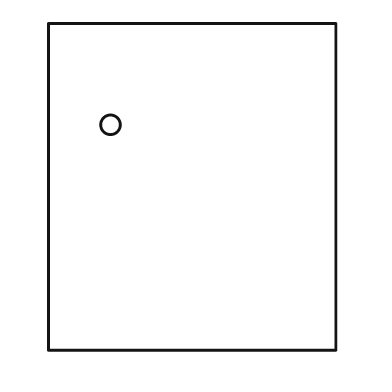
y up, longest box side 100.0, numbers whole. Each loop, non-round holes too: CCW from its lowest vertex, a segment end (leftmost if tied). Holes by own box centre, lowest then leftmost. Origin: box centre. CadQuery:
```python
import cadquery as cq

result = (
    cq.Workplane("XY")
    .moveTo(-44.0, -50.0)
    .lineTo(44.0, -50.0)
    .lineTo(44.0, 50.0)
    .lineTo(-44.0, 50.0)
    .close()
    .moveTo(-25.0, 19.0)
    .circle(3.0)
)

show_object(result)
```